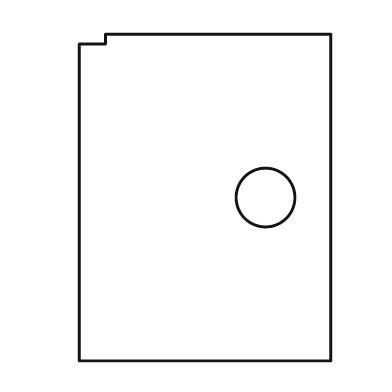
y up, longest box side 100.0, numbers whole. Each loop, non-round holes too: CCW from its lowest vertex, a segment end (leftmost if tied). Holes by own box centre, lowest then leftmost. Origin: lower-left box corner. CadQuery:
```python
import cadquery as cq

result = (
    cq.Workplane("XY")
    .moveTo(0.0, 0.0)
    .lineTo(77.0, 0.0)
    .lineTo(77.0, 100.0)
    .lineTo(8.0, 100.0)
    .lineTo(8.0, 97.0)
    .lineTo(0.0, 97.0)
    .close()
    .moveTo(57.0, 50.0)
    .circle(9.0)
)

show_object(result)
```